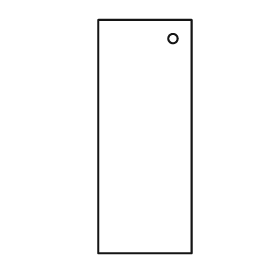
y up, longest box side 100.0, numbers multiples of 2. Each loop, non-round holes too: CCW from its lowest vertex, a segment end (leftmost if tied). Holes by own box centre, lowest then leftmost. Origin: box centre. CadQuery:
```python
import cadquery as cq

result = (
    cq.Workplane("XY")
    .moveTo(-20.0, -50.0)
    .lineTo(20.0, -50.0)
    .lineTo(20.0, 50.0)
    .lineTo(-20.0, 50.0)
    .close()
    .moveTo(12.0, 42.0)
    .circle(2.0)
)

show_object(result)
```